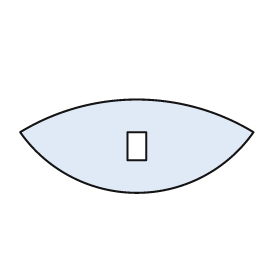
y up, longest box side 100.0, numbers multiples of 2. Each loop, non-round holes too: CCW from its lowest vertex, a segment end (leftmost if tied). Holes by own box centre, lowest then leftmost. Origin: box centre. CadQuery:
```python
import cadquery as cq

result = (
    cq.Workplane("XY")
    .moveTo(-50.0, 6.0)
    .threePointArc((0.0, -20.0), (50.0, 6.0))
    .threePointArc((0.0, 20.0), (-50.0, 6.0))
    .close()
    .moveTo(-4.0, -6.0)
    .lineTo(4.0, -6.0)
    .lineTo(4.0, 6.0)
    .lineTo(-4.0, 6.0)
    .close()
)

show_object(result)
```